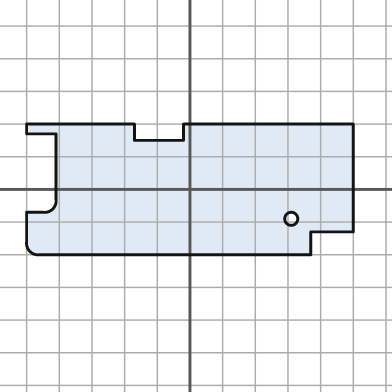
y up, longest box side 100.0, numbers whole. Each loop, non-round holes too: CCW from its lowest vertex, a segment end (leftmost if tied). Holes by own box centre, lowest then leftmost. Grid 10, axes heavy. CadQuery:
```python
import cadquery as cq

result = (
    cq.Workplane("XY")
    .moveTo(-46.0, -20.0)
    .lineTo(37.0, -20.0)
    .lineTo(37.0, -13.0)
    .lineTo(50.0, -13.0)
    .lineTo(50.0, 20.0)
    .lineTo(-2.0, 20.0)
    .lineTo(-2.0, 15.0)
    .lineTo(-17.0, 15.0)
    .lineTo(-17.0, 20.0)
    .lineTo(-50.0, 20.0)
    .lineTo(-50.0, 17.0)
    .lineTo(-41.0, 17.0)
    .lineTo(-41.0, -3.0)
    .threePointArc((-42.0, -6.0), (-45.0, -7.0))
    .lineTo(-50.0, -7.0)
    .lineTo(-50.0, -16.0)
    .threePointArc((-49.0, -19.0), (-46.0, -20.0))
    .close()
    .moveTo(31.0, -9.0)
    .circle(2.0)
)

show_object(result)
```